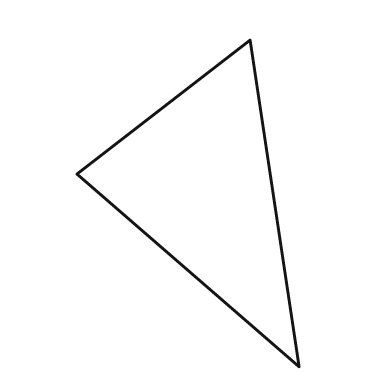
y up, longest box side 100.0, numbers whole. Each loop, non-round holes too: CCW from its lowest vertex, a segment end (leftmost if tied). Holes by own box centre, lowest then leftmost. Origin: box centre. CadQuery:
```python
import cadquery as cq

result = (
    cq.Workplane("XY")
    .moveTo(34.0, -50.0)
    .lineTo(19.0, 50.0)
    .lineTo(-34.0, 9.0)
    .close()
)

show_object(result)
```